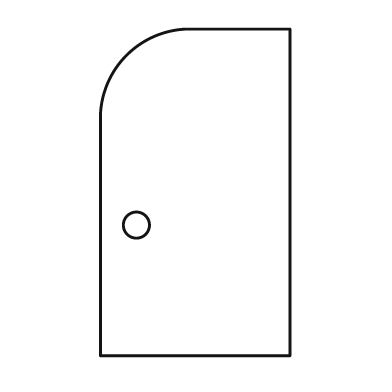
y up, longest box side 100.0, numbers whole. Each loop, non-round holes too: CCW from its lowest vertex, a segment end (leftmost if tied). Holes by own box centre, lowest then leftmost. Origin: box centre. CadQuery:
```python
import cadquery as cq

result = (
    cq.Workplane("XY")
    .moveTo(-29.0, -50.0)
    .lineTo(29.0, -50.0)
    .lineTo(29.0, 50.0)
    .lineTo(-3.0, 50.0)
    .threePointArc((-21.0, 42.0), (-29.0, 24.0))
    .close()
    .moveTo(-18.0, -10.0)
    .circle(4.0)
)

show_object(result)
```